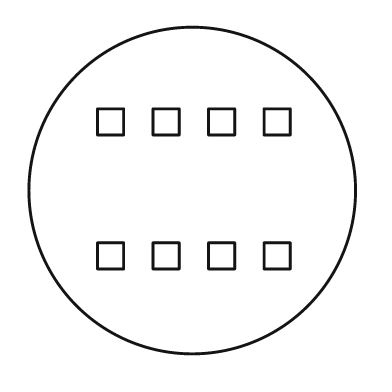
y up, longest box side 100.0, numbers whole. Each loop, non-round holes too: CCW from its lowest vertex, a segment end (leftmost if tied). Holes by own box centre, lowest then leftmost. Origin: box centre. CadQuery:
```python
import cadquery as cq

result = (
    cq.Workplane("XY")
    .moveTo(0.0, 0.0)
    .circle(50.0)
    .moveTo(-29.0, -24.0)
    .lineTo(-21.0, -24.0)
    .lineTo(-21.0, -16.0)
    .lineTo(-29.0, -16.0)
    .close()
    .moveTo(-12.0, -24.0)
    .lineTo(-4.0, -24.0)
    .lineTo(-4.0, -16.0)
    .lineTo(-12.0, -16.0)
    .close()
    .moveTo(5.0, -24.0)
    .lineTo(13.0, -24.0)
    .lineTo(13.0, -16.0)
    .lineTo(5.0, -16.0)
    .close()
    .moveTo(22.0, -24.0)
    .lineTo(30.0, -24.0)
    .lineTo(30.0, -16.0)
    .lineTo(22.0, -16.0)
    .close()
    .moveTo(-29.0, 17.0)
    .lineTo(-21.0, 17.0)
    .lineTo(-21.0, 25.0)
    .lineTo(-29.0, 25.0)
    .close()
    .moveTo(-12.0, 17.0)
    .lineTo(-4.0, 17.0)
    .lineTo(-4.0, 25.0)
    .lineTo(-12.0, 25.0)
    .close()
    .moveTo(5.0, 17.0)
    .lineTo(13.0, 17.0)
    .lineTo(13.0, 25.0)
    .lineTo(5.0, 25.0)
    .close()
    .moveTo(22.0, 17.0)
    .lineTo(30.0, 17.0)
    .lineTo(30.0, 25.0)
    .lineTo(22.0, 25.0)
    .close()
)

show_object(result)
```